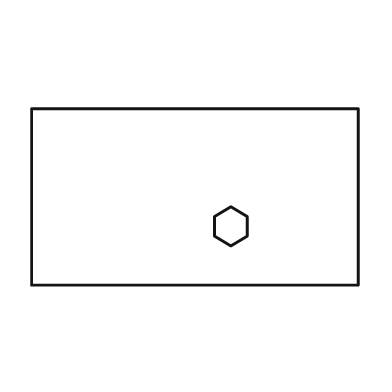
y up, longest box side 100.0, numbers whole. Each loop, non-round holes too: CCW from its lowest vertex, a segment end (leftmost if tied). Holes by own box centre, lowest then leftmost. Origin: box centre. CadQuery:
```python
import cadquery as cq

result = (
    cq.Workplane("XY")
    .moveTo(-50.0, -27.0)
    .lineTo(50.0, -27.0)
    .lineTo(50.0, 27.0)
    .lineTo(-50.0, 27.0)
    .close()
    .moveTo(11.0, -15.0)
    .lineTo(16.0, -12.0)
    .lineTo(16.0, -6.0)
    .lineTo(11.0, -3.0)
    .lineTo(6.0, -6.0)
    .lineTo(6.0, -12.0)
    .close()
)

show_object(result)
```